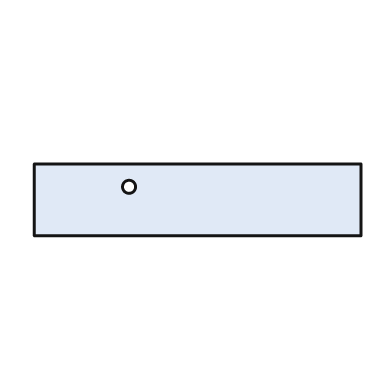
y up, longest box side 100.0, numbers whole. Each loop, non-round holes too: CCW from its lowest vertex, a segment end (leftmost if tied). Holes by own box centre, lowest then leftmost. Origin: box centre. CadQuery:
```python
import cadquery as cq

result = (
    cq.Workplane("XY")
    .moveTo(-50.0, -11.0)
    .lineTo(50.0, -11.0)
    .lineTo(50.0, 11.0)
    .lineTo(-50.0, 11.0)
    .close()
    .moveTo(-21.0, 4.0)
    .circle(2.0)
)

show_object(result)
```